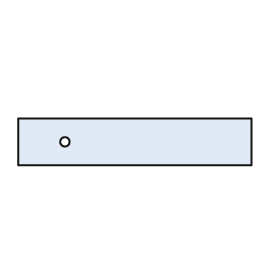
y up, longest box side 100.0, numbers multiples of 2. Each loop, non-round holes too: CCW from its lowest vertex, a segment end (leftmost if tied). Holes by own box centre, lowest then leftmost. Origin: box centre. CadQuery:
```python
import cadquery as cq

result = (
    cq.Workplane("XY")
    .moveTo(-50.0, -10.0)
    .lineTo(50.0, -10.0)
    .lineTo(50.0, 10.0)
    .lineTo(-50.0, 10.0)
    .close()
    .moveTo(-30.0, 0.0)
    .circle(2.0)
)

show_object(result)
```